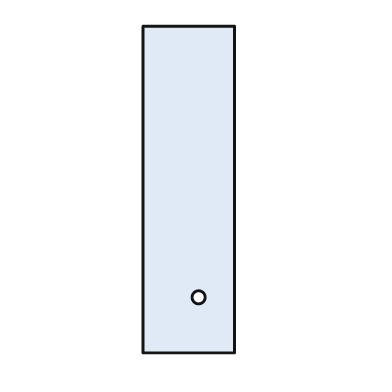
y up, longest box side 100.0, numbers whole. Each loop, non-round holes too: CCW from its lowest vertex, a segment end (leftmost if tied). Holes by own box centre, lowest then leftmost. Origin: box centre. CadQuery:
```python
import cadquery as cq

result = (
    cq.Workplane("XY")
    .moveTo(-14.0, -50.0)
    .lineTo(14.0, -50.0)
    .lineTo(14.0, 50.0)
    .lineTo(-14.0, 50.0)
    .close()
    .moveTo(3.0, -33.0)
    .circle(2.0)
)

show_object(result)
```